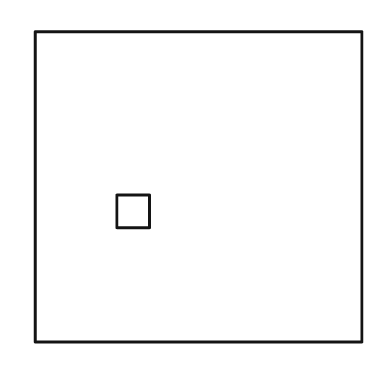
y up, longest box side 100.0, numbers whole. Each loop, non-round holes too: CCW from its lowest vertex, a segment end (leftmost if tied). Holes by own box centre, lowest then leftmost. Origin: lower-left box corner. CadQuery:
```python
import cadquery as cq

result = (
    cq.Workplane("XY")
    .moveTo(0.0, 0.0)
    .lineTo(100.0, 0.0)
    .lineTo(100.0, 95.0)
    .lineTo(0.0, 95.0)
    .close()
    .moveTo(25.0, 35.0)
    .lineTo(35.0, 35.0)
    .lineTo(35.0, 45.0)
    .lineTo(25.0, 45.0)
    .close()
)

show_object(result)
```